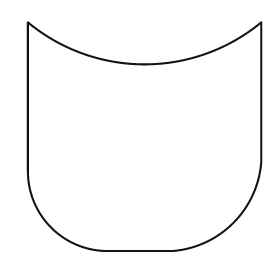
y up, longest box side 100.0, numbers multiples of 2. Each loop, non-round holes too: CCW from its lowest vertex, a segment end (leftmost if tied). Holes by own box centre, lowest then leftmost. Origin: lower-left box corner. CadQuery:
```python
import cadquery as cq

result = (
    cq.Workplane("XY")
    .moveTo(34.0, 0.0)
    .lineTo(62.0, 0.0)
    .threePointArc((88.0, 12.0), (100.0, 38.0))
    .lineTo(100.0, 98.0)
    .threePointArc((50.0, 80.0), (0.0, 98.0))
    .lineTo(0.0, 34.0)
    .threePointArc((10.0, 10.0), (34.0, 0.0))
    .close()
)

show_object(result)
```